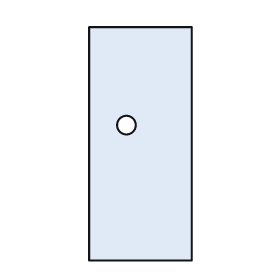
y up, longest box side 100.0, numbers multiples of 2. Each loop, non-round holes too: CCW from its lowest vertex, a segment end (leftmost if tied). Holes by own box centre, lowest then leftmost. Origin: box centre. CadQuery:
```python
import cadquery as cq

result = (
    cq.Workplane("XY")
    .moveTo(-22.0, -50.0)
    .lineTo(22.0, -50.0)
    .lineTo(22.0, 50.0)
    .lineTo(-22.0, 50.0)
    .close()
    .moveTo(-6.0, 8.0)
    .circle(4.0)
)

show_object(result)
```